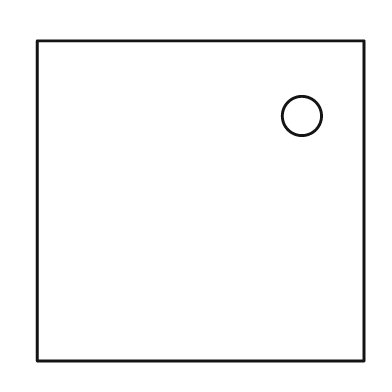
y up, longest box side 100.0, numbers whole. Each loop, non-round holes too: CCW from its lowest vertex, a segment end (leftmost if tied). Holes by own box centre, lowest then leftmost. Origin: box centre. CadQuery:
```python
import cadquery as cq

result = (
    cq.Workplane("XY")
    .moveTo(-50.0, -49.0)
    .lineTo(50.0, -49.0)
    .lineTo(50.0, 49.0)
    .lineTo(-50.0, 49.0)
    .close()
    .moveTo(31.0, 26.0)
    .circle(6.0)
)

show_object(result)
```